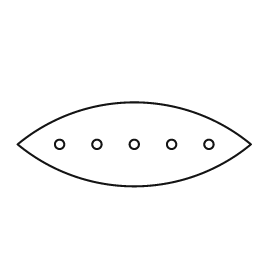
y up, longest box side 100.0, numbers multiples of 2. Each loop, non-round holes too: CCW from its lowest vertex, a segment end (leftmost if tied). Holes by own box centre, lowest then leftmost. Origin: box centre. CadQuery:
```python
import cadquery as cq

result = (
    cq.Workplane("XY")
    .moveTo(-50.0, 0.0)
    .threePointArc((0.0, -18.0), (50.0, 0.0))
    .threePointArc((0.0, 18.0), (-50.0, 0.0))
    .close()
    .moveTo(-32.0, 0.0)
    .circle(2.0)
    .moveTo(-16.0, 0.0)
    .circle(2.0)
    .moveTo(0.0, 0.0)
    .circle(2.0)
    .moveTo(16.0, 0.0)
    .circle(2.0)
    .moveTo(32.0, 0.0)
    .circle(2.0)
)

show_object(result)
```